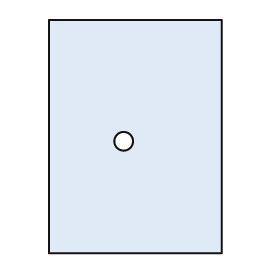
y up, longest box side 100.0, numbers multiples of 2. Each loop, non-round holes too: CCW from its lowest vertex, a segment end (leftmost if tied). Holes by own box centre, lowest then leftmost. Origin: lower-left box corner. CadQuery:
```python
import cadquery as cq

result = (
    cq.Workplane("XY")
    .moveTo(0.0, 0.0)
    .lineTo(74.0, 0.0)
    .lineTo(74.0, 100.0)
    .lineTo(0.0, 100.0)
    .close()
    .moveTo(32.0, 48.0)
    .circle(4.0)
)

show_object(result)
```